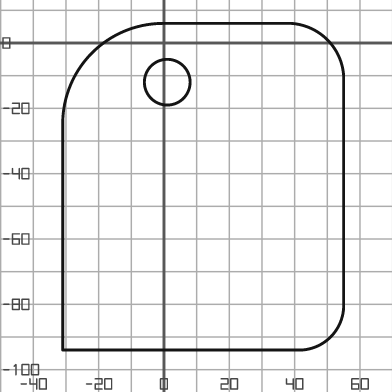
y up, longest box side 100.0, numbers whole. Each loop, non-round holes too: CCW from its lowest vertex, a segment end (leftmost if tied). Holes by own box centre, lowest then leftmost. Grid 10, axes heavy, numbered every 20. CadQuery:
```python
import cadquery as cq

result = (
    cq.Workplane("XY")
    .moveTo(-31.0, -94.0)
    .lineTo(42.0, -94.0)
    .threePointArc((51.0, -90.0), (55.0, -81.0))
    .lineTo(55.0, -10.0)
    .threePointArc((50.0, 1.0), (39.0, 6.0))
    .lineTo(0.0, 6.0)
    .threePointArc((-22.0, -3.0), (-31.0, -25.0))
    .close()
    .moveTo(1.0, -12.0)
    .circle(7.0)
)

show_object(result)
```